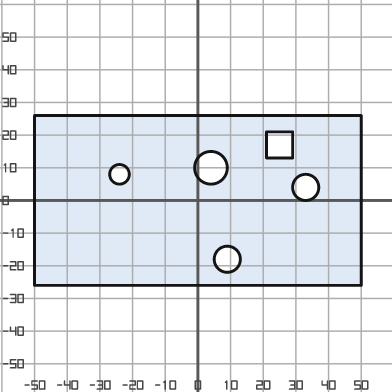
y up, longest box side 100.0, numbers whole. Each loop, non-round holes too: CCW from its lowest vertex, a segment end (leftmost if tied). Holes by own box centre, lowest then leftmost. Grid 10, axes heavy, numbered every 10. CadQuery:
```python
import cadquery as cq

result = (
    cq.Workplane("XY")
    .moveTo(-50.0, -26.0)
    .lineTo(50.0, -26.0)
    .lineTo(50.0, 26.0)
    .lineTo(-50.0, 26.0)
    .close()
    .moveTo(9.0, -18.0)
    .circle(4.0)
    .moveTo(33.0, 4.0)
    .circle(4.0)
    .moveTo(-24.0, 8.0)
    .circle(3.0)
    .moveTo(4.0, 10.0)
    .circle(5.0)
    .moveTo(21.0, 13.0)
    .lineTo(29.0, 13.0)
    .lineTo(29.0, 21.0)
    .lineTo(21.0, 21.0)
    .close()
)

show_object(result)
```